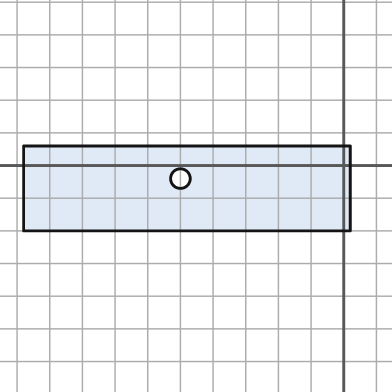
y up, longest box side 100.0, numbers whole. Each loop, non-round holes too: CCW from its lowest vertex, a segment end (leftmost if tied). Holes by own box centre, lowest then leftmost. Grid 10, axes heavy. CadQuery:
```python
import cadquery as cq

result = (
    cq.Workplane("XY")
    .moveTo(-98.0, -20.0)
    .lineTo(2.0, -20.0)
    .lineTo(2.0, 6.0)
    .lineTo(-98.0, 6.0)
    .close()
    .moveTo(-50.0, -4.0)
    .circle(3.0)
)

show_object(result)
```